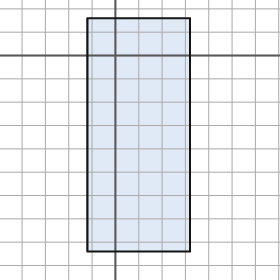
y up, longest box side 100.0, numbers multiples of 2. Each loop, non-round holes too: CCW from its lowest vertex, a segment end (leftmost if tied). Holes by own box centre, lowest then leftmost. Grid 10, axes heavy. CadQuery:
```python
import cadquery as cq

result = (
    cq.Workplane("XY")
    .moveTo(-12.0, -84.0)
    .lineTo(32.0, -84.0)
    .lineTo(32.0, 16.0)
    .lineTo(-12.0, 16.0)
    .close()
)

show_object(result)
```